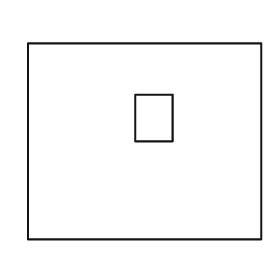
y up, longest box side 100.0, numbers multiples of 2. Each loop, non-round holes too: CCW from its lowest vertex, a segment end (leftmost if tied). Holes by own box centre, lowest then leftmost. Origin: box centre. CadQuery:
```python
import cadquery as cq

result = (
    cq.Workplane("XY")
    .moveTo(-50.0, -42.0)
    .lineTo(50.0, -42.0)
    .lineTo(50.0, 42.0)
    .lineTo(-50.0, 42.0)
    .close()
    .moveTo(-4.0, 0.0)
    .lineTo(12.0, 0.0)
    .lineTo(12.0, 20.0)
    .lineTo(-4.0, 20.0)
    .close()
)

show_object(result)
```